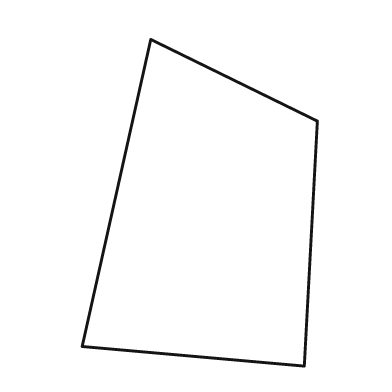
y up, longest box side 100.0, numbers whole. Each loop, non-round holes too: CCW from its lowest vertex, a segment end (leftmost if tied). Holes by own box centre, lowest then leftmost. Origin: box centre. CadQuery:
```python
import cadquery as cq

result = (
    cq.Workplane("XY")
    .moveTo(32.0, -50.0)
    .lineTo(36.0, 25.0)
    .lineTo(-15.0, 50.0)
    .lineTo(-36.0, -44.0)
    .close()
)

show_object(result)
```